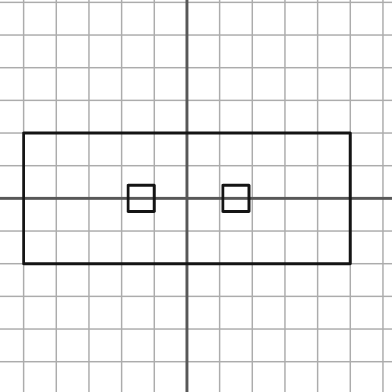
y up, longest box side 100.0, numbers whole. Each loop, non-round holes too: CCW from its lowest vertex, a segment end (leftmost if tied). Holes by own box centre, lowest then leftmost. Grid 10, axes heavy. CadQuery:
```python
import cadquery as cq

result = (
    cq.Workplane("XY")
    .moveTo(-50.0, -20.0)
    .lineTo(50.0, -20.0)
    .lineTo(50.0, 20.0)
    .lineTo(-50.0, 20.0)
    .close()
    .moveTo(-18.0, -4.0)
    .lineTo(-10.0, -4.0)
    .lineTo(-10.0, 4.0)
    .lineTo(-18.0, 4.0)
    .close()
    .moveTo(11.0, -4.0)
    .lineTo(19.0, -4.0)
    .lineTo(19.0, 4.0)
    .lineTo(11.0, 4.0)
    .close()
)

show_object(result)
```